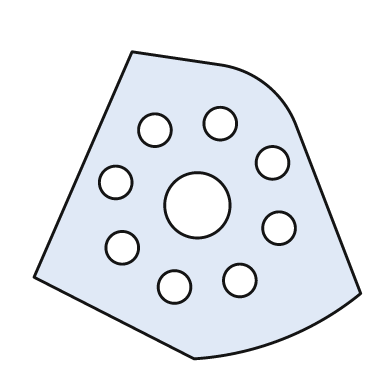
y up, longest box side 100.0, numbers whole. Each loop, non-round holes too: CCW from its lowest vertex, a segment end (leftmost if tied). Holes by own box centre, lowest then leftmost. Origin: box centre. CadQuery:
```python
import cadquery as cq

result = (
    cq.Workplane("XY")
    .moveTo(-1.0, -47.0)
    .threePointArc((26.0, -41.0), (50.0, -27.0))
    .lineTo(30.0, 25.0)
    .threePointArc((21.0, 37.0), (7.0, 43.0))
    .lineTo(-20.0, 47.0)
    .lineTo(-50.0, -22.0)
    .close()
    .moveTo(-7.0, -25.0)
    .circle(5.0)
    .moveTo(13.0, -23.0)
    .circle(5.0)
    .moveTo(-23.0, -13.0)
    .circle(5.0)
    .moveTo(25.0, -7.0)
    .circle(5.0)
    .moveTo(0.0, 0.0)
    .circle(10.0)
    .moveTo(-25.0, 7.0)
    .circle(5.0)
    .moveTo(23.0, 13.0)
    .circle(5.0)
    .moveTo(-13.0, 23.0)
    .circle(5.0)
    .moveTo(7.0, 25.0)
    .circle(5.0)
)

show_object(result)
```